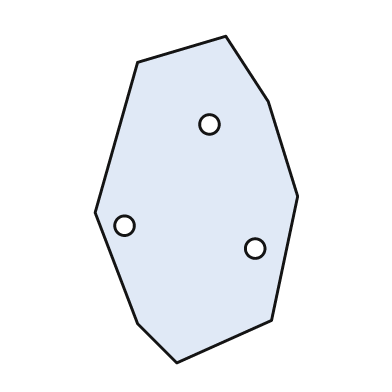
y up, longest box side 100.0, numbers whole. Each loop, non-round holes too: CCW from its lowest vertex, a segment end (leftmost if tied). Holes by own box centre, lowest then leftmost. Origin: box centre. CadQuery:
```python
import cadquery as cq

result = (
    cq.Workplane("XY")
    .moveTo(-6.0, -50.0)
    .lineTo(23.0, -37.0)
    .lineTo(31.0, 1.0)
    .lineTo(22.0, 30.0)
    .lineTo(9.0, 50.0)
    .lineTo(-18.0, 42.0)
    .lineTo(-31.0, -4.0)
    .lineTo(-18.0, -38.0)
    .close()
    .moveTo(18.0, -15.0)
    .circle(3.0)
    .moveTo(-22.0, -8.0)
    .circle(3.0)
    .moveTo(4.0, 23.0)
    .circle(3.0)
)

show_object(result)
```